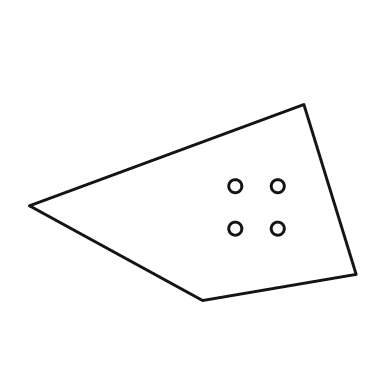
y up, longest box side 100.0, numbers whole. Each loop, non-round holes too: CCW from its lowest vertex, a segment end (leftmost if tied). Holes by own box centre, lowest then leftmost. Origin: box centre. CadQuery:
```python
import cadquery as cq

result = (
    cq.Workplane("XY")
    .moveTo(3.0, -30.0)
    .lineTo(50.0, -22.0)
    .lineTo(34.0, 30.0)
    .lineTo(-50.0, -1.0)
    .close()
    .moveTo(13.0, -8.0)
    .circle(2.0)
    .moveTo(26.0, -8.0)
    .circle(2.0)
    .moveTo(13.0, 5.0)
    .circle(2.0)
    .moveTo(26.0, 5.0)
    .circle(2.0)
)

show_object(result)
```